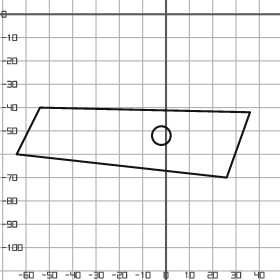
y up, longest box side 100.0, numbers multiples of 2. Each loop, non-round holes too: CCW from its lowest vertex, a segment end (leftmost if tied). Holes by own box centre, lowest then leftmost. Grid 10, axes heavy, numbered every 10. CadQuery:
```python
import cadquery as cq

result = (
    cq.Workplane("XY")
    .moveTo(26.0, -70.0)
    .lineTo(36.0, -42.0)
    .lineTo(-54.0, -40.0)
    .lineTo(-64.0, -60.0)
    .close()
    .moveTo(-2.0, -52.0)
    .circle(4.0)
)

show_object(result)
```